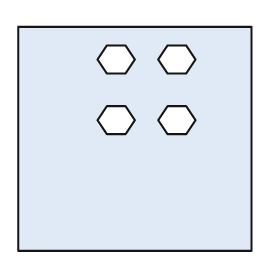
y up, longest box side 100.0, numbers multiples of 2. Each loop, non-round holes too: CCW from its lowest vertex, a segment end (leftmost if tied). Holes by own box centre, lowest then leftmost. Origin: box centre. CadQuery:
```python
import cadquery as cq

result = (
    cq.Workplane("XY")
    .moveTo(-50.0, -48.0)
    .lineTo(50.0, -48.0)
    .lineTo(50.0, 48.0)
    .lineTo(-50.0, 48.0)
    .close()
    .moveTo(-12.0, 2.0)
    .lineTo(-4.0, 2.0)
    .lineTo(0.0, 8.0)
    .lineTo(-4.0, 14.0)
    .lineTo(-12.0, 14.0)
    .lineTo(-16.0, 8.0)
    .close()
    .moveTo(14.0, 2.0)
    .lineTo(22.0, 2.0)
    .lineTo(26.0, 8.0)
    .lineTo(22.0, 14.0)
    .lineTo(14.0, 14.0)
    .lineTo(10.0, 8.0)
    .close()
    .moveTo(-12.0, 28.0)
    .lineTo(-4.0, 28.0)
    .lineTo(0.0, 34.0)
    .lineTo(-4.0, 40.0)
    .lineTo(-12.0, 40.0)
    .lineTo(-16.0, 34.0)
    .close()
    .moveTo(14.0, 28.0)
    .lineTo(22.0, 28.0)
    .lineTo(26.0, 34.0)
    .lineTo(22.0, 40.0)
    .lineTo(14.0, 40.0)
    .lineTo(10.0, 34.0)
    .close()
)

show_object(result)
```